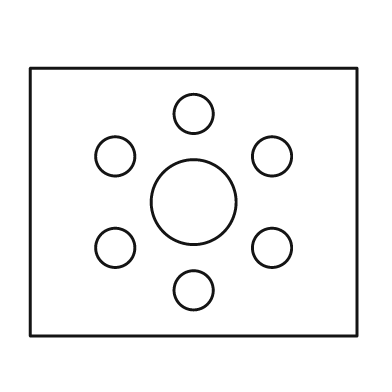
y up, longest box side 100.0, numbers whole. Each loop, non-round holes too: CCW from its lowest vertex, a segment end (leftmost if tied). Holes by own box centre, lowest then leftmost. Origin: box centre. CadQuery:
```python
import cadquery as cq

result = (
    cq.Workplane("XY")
    .moveTo(-50.0, -41.0)
    .lineTo(50.0, -41.0)
    .lineTo(50.0, 41.0)
    .lineTo(-50.0, 41.0)
    .close()
    .moveTo(0.0, -27.0)
    .circle(6.0)
    .moveTo(-24.0, -14.0)
    .circle(6.0)
    .moveTo(24.0, -14.0)
    .circle(6.0)
    .moveTo(0.0, 0.0)
    .circle(13.0)
    .moveTo(-24.0, 14.0)
    .circle(6.0)
    .moveTo(24.0, 14.0)
    .circle(6.0)
    .moveTo(0.0, 27.0)
    .circle(6.0)
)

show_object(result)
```